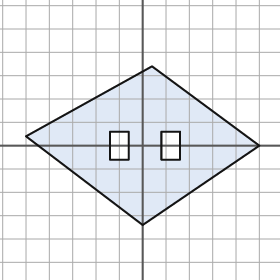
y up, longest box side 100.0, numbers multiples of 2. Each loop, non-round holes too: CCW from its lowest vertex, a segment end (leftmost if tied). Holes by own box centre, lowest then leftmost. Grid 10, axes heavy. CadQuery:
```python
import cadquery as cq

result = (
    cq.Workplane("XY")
    .moveTo(0.0, -34.0)
    .lineTo(50.0, 0.0)
    .lineTo(4.0, 34.0)
    .lineTo(-50.0, 4.0)
    .close()
    .moveTo(-14.0, -6.0)
    .lineTo(-6.0, -6.0)
    .lineTo(-6.0, 6.0)
    .lineTo(-14.0, 6.0)
    .close()
    .moveTo(8.0, -6.0)
    .lineTo(16.0, -6.0)
    .lineTo(16.0, 6.0)
    .lineTo(8.0, 6.0)
    .close()
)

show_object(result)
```